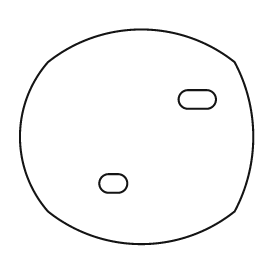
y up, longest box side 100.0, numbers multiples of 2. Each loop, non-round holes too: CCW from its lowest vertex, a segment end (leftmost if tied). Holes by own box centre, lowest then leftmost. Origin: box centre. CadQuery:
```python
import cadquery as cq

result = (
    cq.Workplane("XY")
    .moveTo(-38.0, -32.0)
    .threePointArc((2.0, -46.0), (42.0, -32.0))
    .threePointArc((50.0, 0.0), (42.0, 32.0))
    .threePointArc((2.0, 46.0), (-38.0, 32.0))
    .threePointArc((-50.0, 0.0), (-38.0, -32.0))
    .close()
    .moveTo(-12.0, -24.0)
    .lineTo(-8.0, -24.0)
    .threePointArc((-4.0, -20.0), (-8.0, -16.0))
    .lineTo(-12.0, -16.0)
    .threePointArc((-16.0, -20.0), (-12.0, -24.0))
    .close()
    .moveTo(22.0, 12.0)
    .lineTo(30.0, 12.0)
    .threePointArc((34.0, 16.0), (30.0, 20.0))
    .lineTo(22.0, 20.0)
    .threePointArc((18.0, 16.0), (22.0, 12.0))
    .close()
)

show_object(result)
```